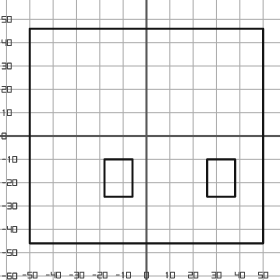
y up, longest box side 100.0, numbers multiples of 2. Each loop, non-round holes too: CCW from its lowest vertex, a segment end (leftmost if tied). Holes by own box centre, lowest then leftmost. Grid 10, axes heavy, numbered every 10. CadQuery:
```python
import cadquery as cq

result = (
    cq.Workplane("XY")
    .moveTo(-50.0, -46.0)
    .lineTo(50.0, -46.0)
    .lineTo(50.0, 46.0)
    .lineTo(-50.0, 46.0)
    .close()
    .moveTo(-18.0, -26.0)
    .lineTo(-6.0, -26.0)
    .lineTo(-6.0, -10.0)
    .lineTo(-18.0, -10.0)
    .close()
    .moveTo(26.0, -26.0)
    .lineTo(38.0, -26.0)
    .lineTo(38.0, -10.0)
    .lineTo(26.0, -10.0)
    .close()
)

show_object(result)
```